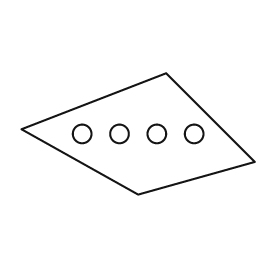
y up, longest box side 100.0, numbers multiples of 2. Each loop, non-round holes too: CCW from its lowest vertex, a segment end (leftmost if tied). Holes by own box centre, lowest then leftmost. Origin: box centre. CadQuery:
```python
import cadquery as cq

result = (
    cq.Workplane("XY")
    .moveTo(0.0, -26.0)
    .lineTo(50.0, -12.0)
    .lineTo(12.0, 26.0)
    .lineTo(-50.0, 2.0)
    .close()
    .moveTo(-24.0, 0.0)
    .circle(4.0)
    .moveTo(-8.0, 0.0)
    .circle(4.0)
    .moveTo(8.0, 0.0)
    .circle(4.0)
    .moveTo(24.0, 0.0)
    .circle(4.0)
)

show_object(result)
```